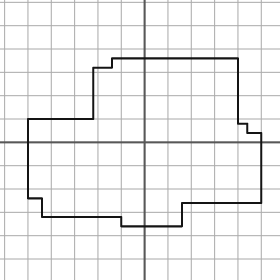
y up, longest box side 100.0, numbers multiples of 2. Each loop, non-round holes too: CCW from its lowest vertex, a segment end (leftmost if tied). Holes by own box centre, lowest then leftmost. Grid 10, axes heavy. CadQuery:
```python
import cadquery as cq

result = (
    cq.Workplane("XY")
    .moveTo(-10.0, -36.0)
    .lineTo(16.0, -36.0)
    .lineTo(16.0, -26.0)
    .lineTo(50.0, -26.0)
    .lineTo(50.0, 4.0)
    .lineTo(44.0, 4.0)
    .lineTo(44.0, 8.0)
    .lineTo(40.0, 8.0)
    .lineTo(40.0, 36.0)
    .lineTo(-14.0, 36.0)
    .lineTo(-14.0, 32.0)
    .lineTo(-22.0, 32.0)
    .lineTo(-22.0, 10.0)
    .lineTo(-50.0, 10.0)
    .lineTo(-50.0, -24.0)
    .lineTo(-44.0, -24.0)
    .lineTo(-44.0, -32.0)
    .lineTo(-10.0, -32.0)
    .close()
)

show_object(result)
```